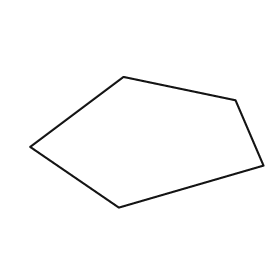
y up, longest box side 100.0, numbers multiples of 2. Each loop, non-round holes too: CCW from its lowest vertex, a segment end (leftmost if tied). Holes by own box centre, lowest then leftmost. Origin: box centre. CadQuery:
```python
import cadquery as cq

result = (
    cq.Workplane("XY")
    .moveTo(-12.0, -28.0)
    .lineTo(50.0, -10.0)
    .lineTo(38.0, 18.0)
    .lineTo(-10.0, 28.0)
    .lineTo(-50.0, -2.0)
    .close()
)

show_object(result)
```